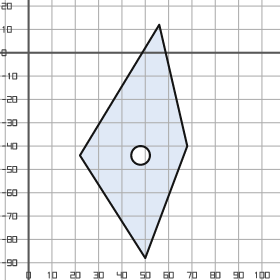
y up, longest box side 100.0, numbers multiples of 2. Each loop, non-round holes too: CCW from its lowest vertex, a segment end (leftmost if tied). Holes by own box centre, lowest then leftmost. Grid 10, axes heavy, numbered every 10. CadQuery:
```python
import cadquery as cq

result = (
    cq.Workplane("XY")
    .moveTo(50.0, -88.0)
    .lineTo(68.0, -40.0)
    .lineTo(56.0, 12.0)
    .lineTo(22.0, -44.0)
    .close()
    .moveTo(48.0, -44.0)
    .circle(4.0)
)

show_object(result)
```